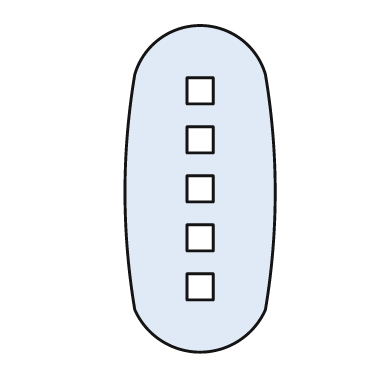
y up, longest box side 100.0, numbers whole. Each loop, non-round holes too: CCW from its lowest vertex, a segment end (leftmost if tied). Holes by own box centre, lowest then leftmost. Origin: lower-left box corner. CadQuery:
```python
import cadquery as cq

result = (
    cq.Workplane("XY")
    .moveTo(3.0, 13.0)
    .threePointArc((23.0, 0.0), (43.0, 13.0))
    .threePointArc((46.0, 49.0), (43.0, 85.0))
    .threePointArc((23.0, 100.0), (3.0, 85.0))
    .threePointArc((0.0, 49.0), (3.0, 13.0))
    .close()
    .moveTo(19.0, 16.0)
    .lineTo(27.0, 16.0)
    .lineTo(27.0, 24.0)
    .lineTo(19.0, 24.0)
    .close()
    .moveTo(19.0, 31.0)
    .lineTo(27.0, 31.0)
    .lineTo(27.0, 39.0)
    .lineTo(19.0, 39.0)
    .close()
    .moveTo(19.0, 46.0)
    .lineTo(27.0, 46.0)
    .lineTo(27.0, 54.0)
    .lineTo(19.0, 54.0)
    .close()
    .moveTo(19.0, 61.0)
    .lineTo(27.0, 61.0)
    .lineTo(27.0, 69.0)
    .lineTo(19.0, 69.0)
    .close()
    .moveTo(19.0, 76.0)
    .lineTo(27.0, 76.0)
    .lineTo(27.0, 84.0)
    .lineTo(19.0, 84.0)
    .close()
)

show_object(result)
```